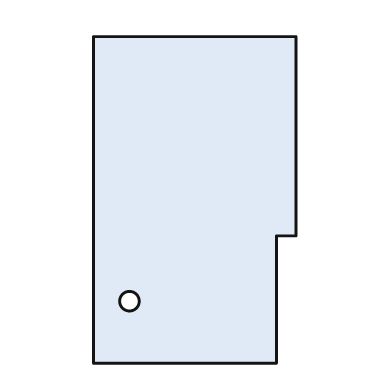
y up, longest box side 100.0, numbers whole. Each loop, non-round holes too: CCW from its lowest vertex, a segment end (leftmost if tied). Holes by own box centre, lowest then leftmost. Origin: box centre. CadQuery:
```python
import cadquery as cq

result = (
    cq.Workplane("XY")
    .moveTo(-31.0, -50.0)
    .lineTo(25.0, -50.0)
    .lineTo(25.0, -11.0)
    .lineTo(31.0, -11.0)
    .lineTo(31.0, 50.0)
    .lineTo(-31.0, 50.0)
    .close()
    .moveTo(-20.0, -31.0)
    .circle(3.0)
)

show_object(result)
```